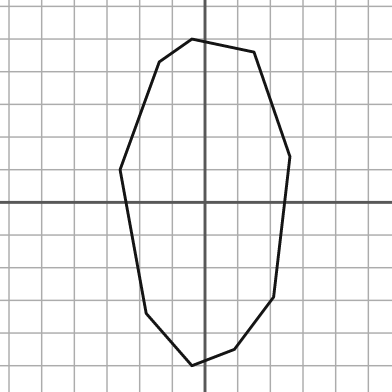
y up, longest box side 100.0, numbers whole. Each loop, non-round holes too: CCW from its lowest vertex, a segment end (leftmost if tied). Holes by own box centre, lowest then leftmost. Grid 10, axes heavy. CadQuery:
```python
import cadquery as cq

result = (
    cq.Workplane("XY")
    .moveTo(-4.0, -50.0)
    .lineTo(9.0, -45.0)
    .lineTo(21.0, -29.0)
    .lineTo(26.0, 14.0)
    .lineTo(15.0, 46.0)
    .lineTo(-4.0, 50.0)
    .lineTo(-14.0, 43.0)
    .lineTo(-26.0, 10.0)
    .lineTo(-18.0, -34.0)
    .close()
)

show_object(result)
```